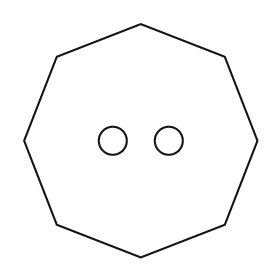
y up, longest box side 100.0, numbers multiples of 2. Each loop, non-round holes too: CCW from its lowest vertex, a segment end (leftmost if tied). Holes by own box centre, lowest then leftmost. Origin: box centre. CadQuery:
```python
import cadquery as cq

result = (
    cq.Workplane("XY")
    .moveTo(0.0, -50.0)
    .lineTo(36.0, -36.0)
    .lineTo(50.0, 0.0)
    .lineTo(36.0, 36.0)
    .lineTo(0.0, 50.0)
    .lineTo(-36.0, 36.0)
    .lineTo(-50.0, 0.0)
    .lineTo(-36.0, -36.0)
    .close()
    .moveTo(-12.0, 0.0)
    .circle(6.0)
    .moveTo(12.0, 0.0)
    .circle(6.0)
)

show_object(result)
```